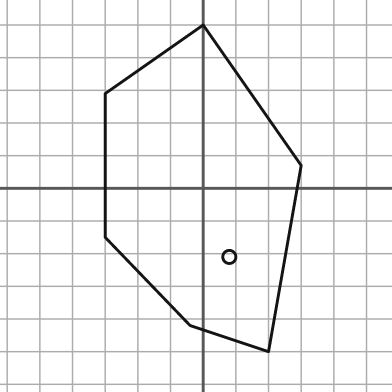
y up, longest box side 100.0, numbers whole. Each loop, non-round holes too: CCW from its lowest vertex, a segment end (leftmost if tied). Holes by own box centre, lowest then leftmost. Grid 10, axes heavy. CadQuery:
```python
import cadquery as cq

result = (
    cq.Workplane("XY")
    .moveTo(20.0, -50.0)
    .lineTo(30.0, 7.0)
    .lineTo(0.0, 50.0)
    .lineTo(-30.0, 29.0)
    .lineTo(-30.0, -15.0)
    .lineTo(-4.0, -42.0)
    .close()
    .moveTo(8.0, -21.0)
    .circle(2.0)
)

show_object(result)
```